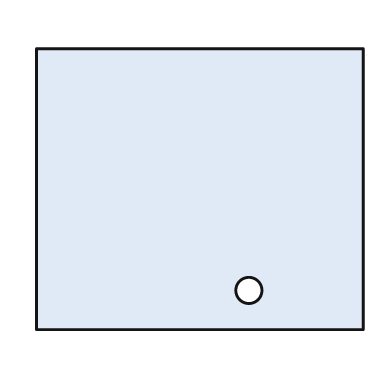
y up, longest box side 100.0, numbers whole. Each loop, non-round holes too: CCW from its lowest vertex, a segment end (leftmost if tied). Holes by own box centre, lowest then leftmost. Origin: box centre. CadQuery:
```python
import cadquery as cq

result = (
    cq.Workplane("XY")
    .moveTo(-50.0, -43.0)
    .lineTo(50.0, -43.0)
    .lineTo(50.0, 43.0)
    .lineTo(-50.0, 43.0)
    .close()
    .moveTo(15.0, -31.0)
    .circle(4.0)
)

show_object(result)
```